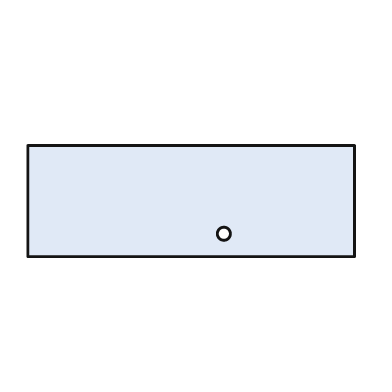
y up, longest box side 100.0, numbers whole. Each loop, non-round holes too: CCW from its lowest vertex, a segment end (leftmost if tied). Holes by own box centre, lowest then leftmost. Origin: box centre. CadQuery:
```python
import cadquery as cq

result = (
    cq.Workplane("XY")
    .moveTo(-50.0, -17.0)
    .lineTo(50.0, -17.0)
    .lineTo(50.0, 17.0)
    .lineTo(-50.0, 17.0)
    .close()
    .moveTo(10.0, -10.0)
    .circle(2.0)
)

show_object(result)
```